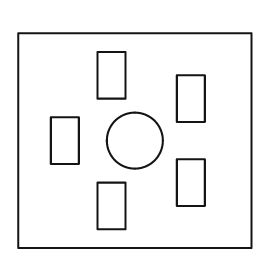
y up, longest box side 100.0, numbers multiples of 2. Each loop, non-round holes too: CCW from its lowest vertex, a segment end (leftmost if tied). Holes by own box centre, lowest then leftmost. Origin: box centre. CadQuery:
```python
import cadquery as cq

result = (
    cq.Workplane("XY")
    .moveTo(-50.0, -46.0)
    .lineTo(50.0, -46.0)
    .lineTo(50.0, 46.0)
    .lineTo(-50.0, 46.0)
    .close()
    .moveTo(-16.0, -38.0)
    .lineTo(-4.0, -38.0)
    .lineTo(-4.0, -18.0)
    .lineTo(-16.0, -18.0)
    .close()
    .moveTo(18.0, -28.0)
    .lineTo(30.0, -28.0)
    .lineTo(30.0, -8.0)
    .lineTo(18.0, -8.0)
    .close()
    .moveTo(-36.0, -10.0)
    .lineTo(-24.0, -10.0)
    .lineTo(-24.0, 10.0)
    .lineTo(-36.0, 10.0)
    .close()
    .moveTo(0.0, 0.0)
    .circle(12.0)
    .moveTo(18.0, 8.0)
    .lineTo(30.0, 8.0)
    .lineTo(30.0, 28.0)
    .lineTo(18.0, 28.0)
    .close()
    .moveTo(-16.0, 18.0)
    .lineTo(-4.0, 18.0)
    .lineTo(-4.0, 38.0)
    .lineTo(-16.0, 38.0)
    .close()
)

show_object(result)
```